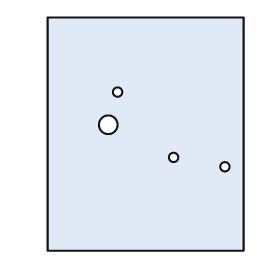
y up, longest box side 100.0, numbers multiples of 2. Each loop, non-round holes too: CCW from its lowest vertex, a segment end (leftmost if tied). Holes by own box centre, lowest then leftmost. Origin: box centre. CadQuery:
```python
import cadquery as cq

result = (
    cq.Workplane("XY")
    .moveTo(-42.0, -50.0)
    .lineTo(42.0, -50.0)
    .lineTo(42.0, 50.0)
    .lineTo(-42.0, 50.0)
    .close()
    .moveTo(34.0, -14.0)
    .circle(2.0)
    .moveTo(12.0, -10.0)
    .circle(2.0)
    .moveTo(-16.0, 4.0)
    .circle(4.0)
    .moveTo(-12.0, 18.0)
    .circle(2.0)
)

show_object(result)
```